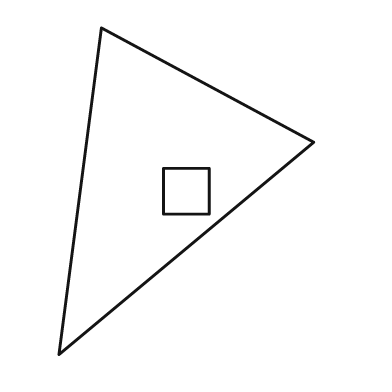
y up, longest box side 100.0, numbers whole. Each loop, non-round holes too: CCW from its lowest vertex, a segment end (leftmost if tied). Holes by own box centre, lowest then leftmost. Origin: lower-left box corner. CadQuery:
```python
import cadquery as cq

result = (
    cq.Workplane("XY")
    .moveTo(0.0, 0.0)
    .lineTo(78.0, 65.0)
    .lineTo(13.0, 100.0)
    .close()
    .moveTo(32.0, 43.0)
    .lineTo(46.0, 43.0)
    .lineTo(46.0, 57.0)
    .lineTo(32.0, 57.0)
    .close()
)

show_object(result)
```